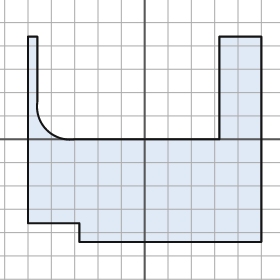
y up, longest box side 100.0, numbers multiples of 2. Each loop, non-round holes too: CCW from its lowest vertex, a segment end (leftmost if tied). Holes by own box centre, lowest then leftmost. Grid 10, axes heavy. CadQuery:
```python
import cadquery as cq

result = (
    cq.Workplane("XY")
    .moveTo(-28.0, -44.0)
    .lineTo(50.0, -44.0)
    .lineTo(50.0, 44.0)
    .lineTo(32.0, 44.0)
    .lineTo(32.0, 0.0)
    .lineTo(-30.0, 0.0)
    .threePointArc((-42.0, 4.0), (-46.0, 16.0))
    .lineTo(-46.0, 44.0)
    .lineTo(-50.0, 44.0)
    .lineTo(-50.0, -36.0)
    .lineTo(-28.0, -36.0)
    .close()
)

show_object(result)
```